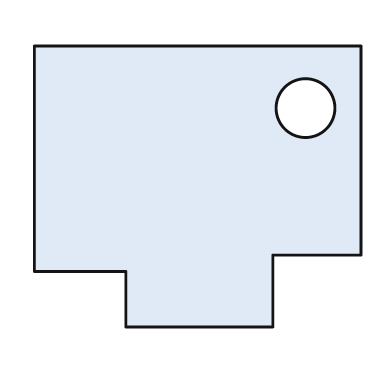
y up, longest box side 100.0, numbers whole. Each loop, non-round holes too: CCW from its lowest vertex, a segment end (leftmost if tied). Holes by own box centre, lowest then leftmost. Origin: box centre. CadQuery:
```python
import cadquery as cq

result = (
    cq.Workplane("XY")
    .moveTo(-22.0, -43.0)
    .lineTo(23.0, -43.0)
    .lineTo(23.0, -21.0)
    .lineTo(50.0, -21.0)
    .lineTo(50.0, 43.0)
    .lineTo(-50.0, 43.0)
    .lineTo(-50.0, -26.0)
    .lineTo(-22.0, -26.0)
    .close()
    .moveTo(33.0, 24.0)
    .circle(9.0)
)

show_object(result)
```